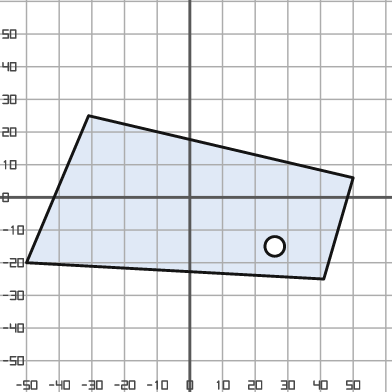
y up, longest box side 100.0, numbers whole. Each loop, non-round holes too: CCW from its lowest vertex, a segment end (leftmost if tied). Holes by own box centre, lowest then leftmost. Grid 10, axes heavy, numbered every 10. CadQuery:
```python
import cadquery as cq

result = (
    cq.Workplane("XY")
    .moveTo(41.0, -25.0)
    .lineTo(50.0, 6.0)
    .lineTo(-31.0, 25.0)
    .lineTo(-50.0, -20.0)
    .close()
    .moveTo(26.0, -15.0)
    .circle(3.0)
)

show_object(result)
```